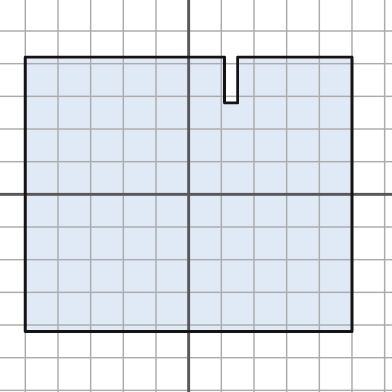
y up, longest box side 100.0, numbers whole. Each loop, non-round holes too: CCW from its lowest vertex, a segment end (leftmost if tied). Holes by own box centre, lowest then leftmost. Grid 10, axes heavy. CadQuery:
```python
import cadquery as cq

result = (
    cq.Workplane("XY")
    .moveTo(-50.0, -42.0)
    .lineTo(50.0, -42.0)
    .lineTo(50.0, 42.0)
    .lineTo(15.0, 42.0)
    .lineTo(15.0, 28.0)
    .lineTo(11.0, 28.0)
    .lineTo(11.0, 42.0)
    .lineTo(-50.0, 42.0)
    .close()
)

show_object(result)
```